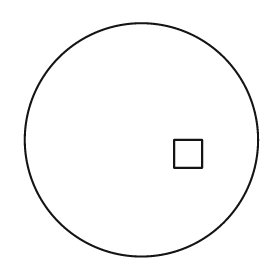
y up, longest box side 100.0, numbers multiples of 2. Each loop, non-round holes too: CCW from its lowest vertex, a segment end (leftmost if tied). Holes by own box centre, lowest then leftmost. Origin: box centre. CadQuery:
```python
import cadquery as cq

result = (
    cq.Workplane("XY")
    .moveTo(0.0, 0.0)
    .circle(50.0)
    .moveTo(14.0, -12.0)
    .lineTo(26.0, -12.0)
    .lineTo(26.0, 0.0)
    .lineTo(14.0, 0.0)
    .close()
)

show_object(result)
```